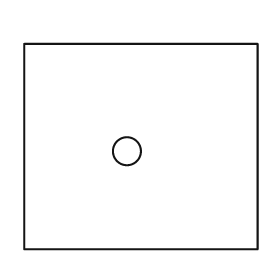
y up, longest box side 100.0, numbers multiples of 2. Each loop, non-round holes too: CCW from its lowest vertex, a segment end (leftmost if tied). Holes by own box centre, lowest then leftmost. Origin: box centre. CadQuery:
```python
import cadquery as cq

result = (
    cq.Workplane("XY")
    .moveTo(-50.0, -44.0)
    .lineTo(50.0, -44.0)
    .lineTo(50.0, 44.0)
    .lineTo(-50.0, 44.0)
    .close()
    .moveTo(-6.0, -2.0)
    .circle(6.0)
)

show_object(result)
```